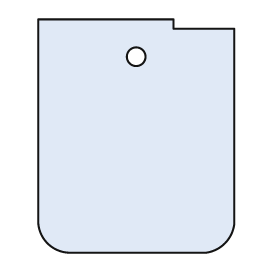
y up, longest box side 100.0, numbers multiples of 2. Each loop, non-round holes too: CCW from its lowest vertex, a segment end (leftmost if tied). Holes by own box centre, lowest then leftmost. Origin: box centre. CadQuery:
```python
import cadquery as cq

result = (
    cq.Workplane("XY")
    .moveTo(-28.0, -50.0)
    .lineTo(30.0, -50.0)
    .threePointArc((38.0, -46.0), (42.0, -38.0))
    .lineTo(42.0, 46.0)
    .lineTo(16.0, 46.0)
    .lineTo(16.0, 50.0)
    .lineTo(-42.0, 50.0)
    .lineTo(-42.0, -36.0)
    .threePointArc((-38.0, -46.0), (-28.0, -50.0))
    .close()
    .moveTo(0.0, 34.0)
    .circle(4.0)
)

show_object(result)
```